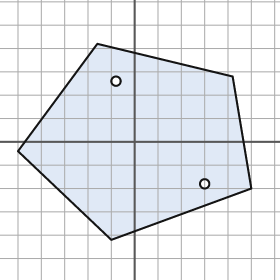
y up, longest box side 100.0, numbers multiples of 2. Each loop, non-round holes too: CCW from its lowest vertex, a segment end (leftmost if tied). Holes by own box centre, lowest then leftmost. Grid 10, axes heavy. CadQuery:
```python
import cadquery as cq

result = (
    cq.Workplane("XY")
    .moveTo(-10.0, -42.0)
    .lineTo(50.0, -20.0)
    .lineTo(42.0, 28.0)
    .lineTo(-16.0, 42.0)
    .lineTo(-50.0, -4.0)
    .close()
    .moveTo(30.0, -18.0)
    .circle(2.0)
    .moveTo(-8.0, 26.0)
    .circle(2.0)
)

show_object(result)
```